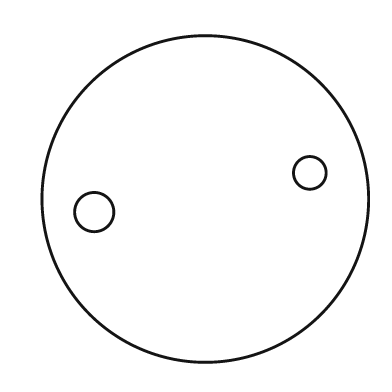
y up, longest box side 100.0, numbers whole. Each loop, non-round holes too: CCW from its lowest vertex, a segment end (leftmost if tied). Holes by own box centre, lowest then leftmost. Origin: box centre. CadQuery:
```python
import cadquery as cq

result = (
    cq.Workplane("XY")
    .moveTo(0.0, 0.0)
    .circle(50.0)
    .moveTo(-34.0, -4.0)
    .circle(6.0)
    .moveTo(32.0, 8.0)
    .circle(5.0)
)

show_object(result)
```